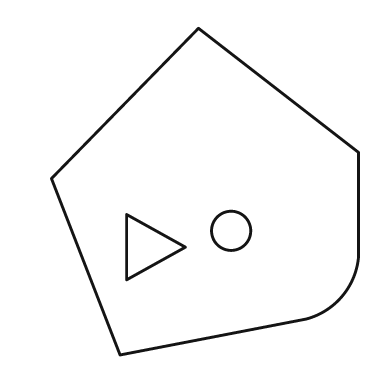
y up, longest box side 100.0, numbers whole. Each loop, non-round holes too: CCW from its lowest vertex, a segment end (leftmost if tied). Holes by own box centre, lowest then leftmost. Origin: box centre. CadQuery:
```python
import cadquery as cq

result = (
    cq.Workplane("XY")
    .moveTo(-26.0, -50.0)
    .lineTo(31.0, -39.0)
    .threePointArc((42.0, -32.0), (47.0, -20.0))
    .lineTo(47.0, 12.0)
    .lineTo(-2.0, 50.0)
    .lineTo(-47.0, 4.0)
    .close()
    .moveTo(-24.0, -27.0)
    .lineTo(-6.0, -17.0)
    .lineTo(-24.0, -7.0)
    .close()
    .moveTo(8.0, -12.0)
    .circle(6.0)
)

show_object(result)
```